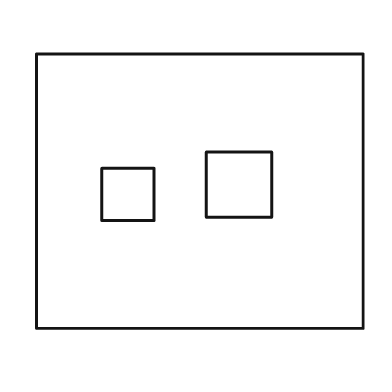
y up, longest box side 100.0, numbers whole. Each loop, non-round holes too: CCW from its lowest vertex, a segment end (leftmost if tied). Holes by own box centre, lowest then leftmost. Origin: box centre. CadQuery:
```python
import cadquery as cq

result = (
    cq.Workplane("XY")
    .moveTo(-50.0, -42.0)
    .lineTo(50.0, -42.0)
    .lineTo(50.0, 42.0)
    .lineTo(-50.0, 42.0)
    .close()
    .moveTo(-30.0, -9.0)
    .lineTo(-14.0, -9.0)
    .lineTo(-14.0, 7.0)
    .lineTo(-30.0, 7.0)
    .close()
    .moveTo(2.0, -8.0)
    .lineTo(22.0, -8.0)
    .lineTo(22.0, 12.0)
    .lineTo(2.0, 12.0)
    .close()
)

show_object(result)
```